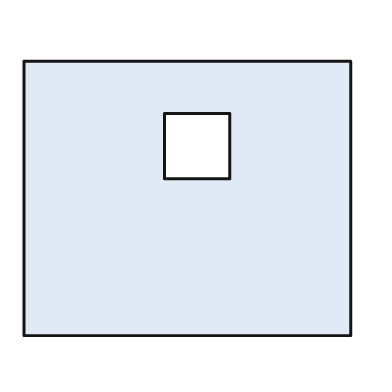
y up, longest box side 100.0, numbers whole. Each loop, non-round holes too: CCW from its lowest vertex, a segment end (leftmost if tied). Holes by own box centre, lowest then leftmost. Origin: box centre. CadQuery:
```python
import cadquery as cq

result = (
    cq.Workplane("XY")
    .moveTo(-50.0, -42.0)
    .lineTo(50.0, -42.0)
    .lineTo(50.0, 42.0)
    .lineTo(-50.0, 42.0)
    .close()
    .moveTo(-7.0, 6.0)
    .lineTo(13.0, 6.0)
    .lineTo(13.0, 26.0)
    .lineTo(-7.0, 26.0)
    .close()
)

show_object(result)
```